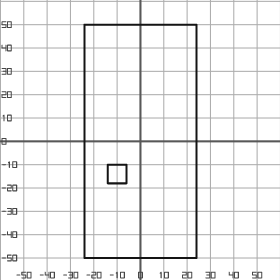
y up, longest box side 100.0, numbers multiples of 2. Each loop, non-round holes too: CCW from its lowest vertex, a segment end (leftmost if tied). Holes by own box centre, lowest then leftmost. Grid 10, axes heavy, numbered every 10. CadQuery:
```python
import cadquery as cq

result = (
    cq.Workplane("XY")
    .moveTo(-24.0, -50.0)
    .lineTo(24.0, -50.0)
    .lineTo(24.0, 50.0)
    .lineTo(-24.0, 50.0)
    .close()
    .moveTo(-14.0, -18.0)
    .lineTo(-6.0, -18.0)
    .lineTo(-6.0, -10.0)
    .lineTo(-14.0, -10.0)
    .close()
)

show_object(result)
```